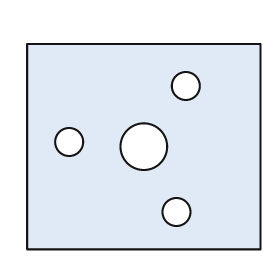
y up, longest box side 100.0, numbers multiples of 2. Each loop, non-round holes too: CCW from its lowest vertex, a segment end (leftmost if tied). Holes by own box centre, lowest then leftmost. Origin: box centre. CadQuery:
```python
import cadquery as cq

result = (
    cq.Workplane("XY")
    .moveTo(-50.0, -44.0)
    .lineTo(50.0, -44.0)
    .lineTo(50.0, 44.0)
    .lineTo(-50.0, 44.0)
    .close()
    .moveTo(14.0, -28.0)
    .circle(6.0)
    .moveTo(0.0, 0.0)
    .circle(10.0)
    .moveTo(-32.0, 2.0)
    .circle(6.0)
    .moveTo(18.0, 26.0)
    .circle(6.0)
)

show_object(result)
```